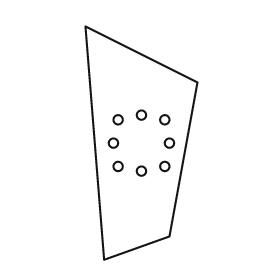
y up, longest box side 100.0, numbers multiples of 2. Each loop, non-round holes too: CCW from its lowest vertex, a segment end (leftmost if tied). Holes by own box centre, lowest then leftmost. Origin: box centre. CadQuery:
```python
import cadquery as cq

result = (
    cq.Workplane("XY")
    .moveTo(-16.0, -50.0)
    .lineTo(12.0, -40.0)
    .lineTo(24.0, 26.0)
    .lineTo(-24.0, 50.0)
    .close()
    .moveTo(0.0, -12.0)
    .circle(2.0)
    .moveTo(-10.0, -10.0)
    .circle(2.0)
    .moveTo(10.0, -10.0)
    .circle(2.0)
    .moveTo(-12.0, 0.0)
    .circle(2.0)
    .moveTo(12.0, 0.0)
    .circle(2.0)
    .moveTo(-10.0, 10.0)
    .circle(2.0)
    .moveTo(10.0, 10.0)
    .circle(2.0)
    .moveTo(0.0, 12.0)
    .circle(2.0)
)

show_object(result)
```